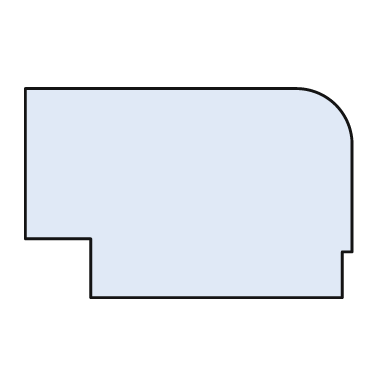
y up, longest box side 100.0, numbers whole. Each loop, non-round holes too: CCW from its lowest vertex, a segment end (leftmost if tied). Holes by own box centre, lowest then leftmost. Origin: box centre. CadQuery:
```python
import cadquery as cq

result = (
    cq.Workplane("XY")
    .moveTo(-30.0, -32.0)
    .lineTo(47.0, -32.0)
    .lineTo(47.0, -18.0)
    .lineTo(50.0, -18.0)
    .lineTo(50.0, 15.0)
    .threePointArc((45.0, 27.0), (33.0, 32.0))
    .lineTo(-50.0, 32.0)
    .lineTo(-50.0, -14.0)
    .lineTo(-30.0, -14.0)
    .close()
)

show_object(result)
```